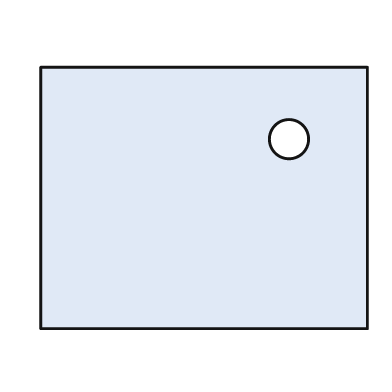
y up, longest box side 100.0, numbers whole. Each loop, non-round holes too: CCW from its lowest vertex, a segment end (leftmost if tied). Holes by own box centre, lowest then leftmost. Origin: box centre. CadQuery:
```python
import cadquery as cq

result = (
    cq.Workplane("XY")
    .moveTo(-50.0, -40.0)
    .lineTo(50.0, -40.0)
    .lineTo(50.0, 40.0)
    .lineTo(-50.0, 40.0)
    .close()
    .moveTo(26.0, 18.0)
    .circle(6.0)
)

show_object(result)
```